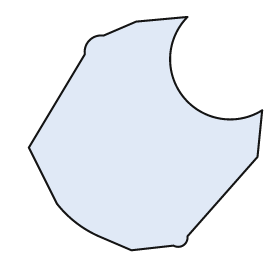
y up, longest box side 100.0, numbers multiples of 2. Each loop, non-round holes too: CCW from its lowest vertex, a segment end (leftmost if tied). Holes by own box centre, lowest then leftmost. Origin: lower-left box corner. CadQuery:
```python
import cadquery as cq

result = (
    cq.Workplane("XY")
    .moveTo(44.0, 0.0)
    .lineTo(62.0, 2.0)
    .threePointArc((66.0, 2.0), (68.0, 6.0))
    .lineTo(98.0, 40.0)
    .lineTo(100.0, 60.0)
    .threePointArc((66.0, 66.0), (68.0, 100.0))
    .lineTo(46.0, 98.0)
    .lineTo(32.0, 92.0)
    .threePointArc((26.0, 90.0), (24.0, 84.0))
    .lineTo(0.0, 44.0)
    .lineTo(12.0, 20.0)
    .threePointArc((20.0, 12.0), (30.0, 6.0))
    .close()
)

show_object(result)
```